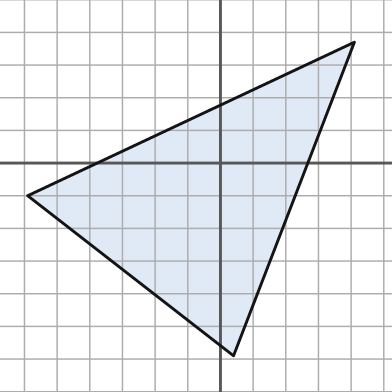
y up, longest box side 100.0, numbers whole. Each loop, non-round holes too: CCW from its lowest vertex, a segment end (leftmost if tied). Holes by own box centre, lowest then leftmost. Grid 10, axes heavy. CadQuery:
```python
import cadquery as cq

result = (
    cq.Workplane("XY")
    .moveTo(4.0, -59.0)
    .lineTo(41.0, 37.0)
    .lineTo(-59.0, -10.0)
    .close()
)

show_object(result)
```